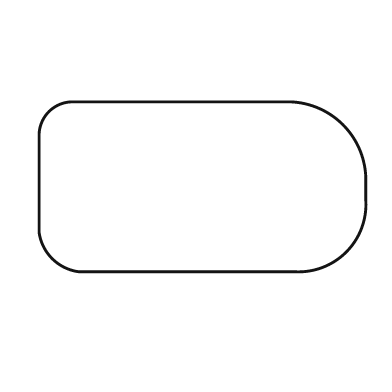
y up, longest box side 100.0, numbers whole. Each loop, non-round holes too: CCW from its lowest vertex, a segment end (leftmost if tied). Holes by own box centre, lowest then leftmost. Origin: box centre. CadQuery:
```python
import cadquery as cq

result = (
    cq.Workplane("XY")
    .moveTo(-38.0, -26.0)
    .lineTo(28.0, -26.0)
    .threePointArc((44.0, -20.0), (50.0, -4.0))
    .lineTo(50.0, 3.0)
    .threePointArc((43.0, 19.0), (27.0, 26.0))
    .lineTo(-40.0, 26.0)
    .threePointArc((-47.0, 23.0), (-50.0, 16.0))
    .lineTo(-50.0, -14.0)
    .threePointArc((-46.0, -22.0), (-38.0, -26.0))
    .close()
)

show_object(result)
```